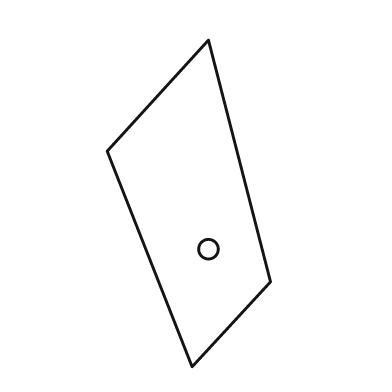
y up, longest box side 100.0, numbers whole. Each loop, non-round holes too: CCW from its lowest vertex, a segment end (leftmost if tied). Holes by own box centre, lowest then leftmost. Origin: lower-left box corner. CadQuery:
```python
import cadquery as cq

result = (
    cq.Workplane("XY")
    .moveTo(26.0, 0.0)
    .lineTo(50.0, 26.0)
    .lineTo(31.0, 100.0)
    .lineTo(0.0, 66.0)
    .close()
    .moveTo(31.0, 36.0)
    .circle(3.0)
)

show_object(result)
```